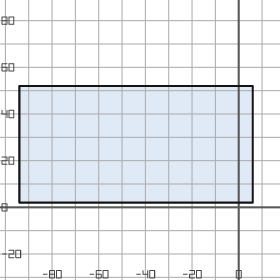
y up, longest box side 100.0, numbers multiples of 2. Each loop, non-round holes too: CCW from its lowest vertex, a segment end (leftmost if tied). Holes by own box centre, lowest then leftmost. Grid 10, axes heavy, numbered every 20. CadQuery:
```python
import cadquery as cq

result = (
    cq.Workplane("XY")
    .moveTo(-94.0, 2.0)
    .lineTo(6.0, 2.0)
    .lineTo(6.0, 52.0)
    .lineTo(-94.0, 52.0)
    .close()
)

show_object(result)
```